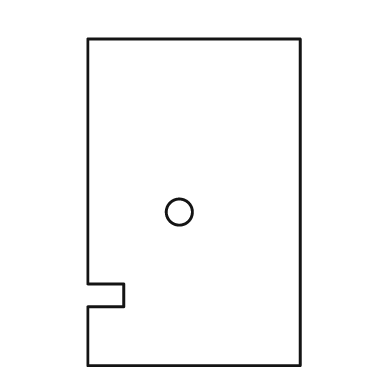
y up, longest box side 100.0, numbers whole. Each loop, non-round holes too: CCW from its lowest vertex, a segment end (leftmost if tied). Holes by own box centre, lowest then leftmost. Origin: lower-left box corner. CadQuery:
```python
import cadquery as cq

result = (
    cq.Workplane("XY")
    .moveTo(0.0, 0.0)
    .lineTo(65.0, 0.0)
    .lineTo(65.0, 100.0)
    .lineTo(0.0, 100.0)
    .lineTo(0.0, 25.0)
    .lineTo(11.0, 25.0)
    .lineTo(11.0, 18.0)
    .lineTo(0.0, 18.0)
    .close()
    .moveTo(28.0, 47.0)
    .circle(4.0)
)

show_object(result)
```